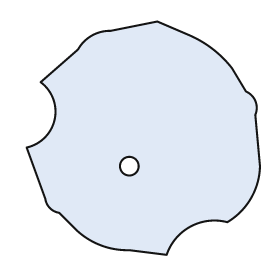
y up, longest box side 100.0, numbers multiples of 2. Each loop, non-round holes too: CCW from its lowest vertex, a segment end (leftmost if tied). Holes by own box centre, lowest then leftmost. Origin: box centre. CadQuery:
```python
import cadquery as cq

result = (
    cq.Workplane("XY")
    .moveTo(10.0, -50.0)
    .threePointArc((20.0, -38.0), (36.0, -36.0))
    .threePointArc((46.0, -26.0), (50.0, -12.0))
    .lineTo(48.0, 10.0)
    .threePointArc((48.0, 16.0), (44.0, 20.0))
    .lineTo(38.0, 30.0)
    .threePointArc((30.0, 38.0), (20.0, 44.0))
    .lineTo(6.0, 50.0)
    .lineTo(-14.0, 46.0)
    .threePointArc((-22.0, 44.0), (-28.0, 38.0))
    .lineTo(-44.0, 24.0)
    .threePointArc((-38.0, 8.0), (-50.0, -4.0))
    .lineTo(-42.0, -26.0)
    .threePointArc((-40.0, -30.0), (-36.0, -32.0))
    .lineTo(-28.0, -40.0)
    .threePointArc((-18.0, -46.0), (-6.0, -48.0))
    .close()
    .moveTo(-6.0, -12.0)
    .circle(4.0)
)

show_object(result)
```